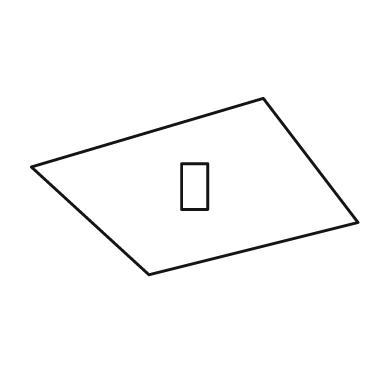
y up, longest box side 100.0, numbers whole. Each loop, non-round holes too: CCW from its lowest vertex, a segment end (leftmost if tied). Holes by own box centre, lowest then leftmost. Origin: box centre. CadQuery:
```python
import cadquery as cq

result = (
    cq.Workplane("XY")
    .moveTo(-14.0, -27.0)
    .lineTo(50.0, -11.0)
    .lineTo(21.0, 27.0)
    .lineTo(-50.0, 6.0)
    .close()
    .moveTo(-4.0, -7.0)
    .lineTo(4.0, -7.0)
    .lineTo(4.0, 7.0)
    .lineTo(-4.0, 7.0)
    .close()
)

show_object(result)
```